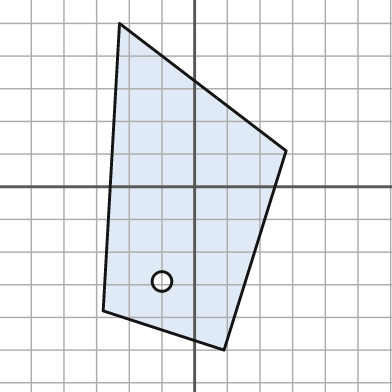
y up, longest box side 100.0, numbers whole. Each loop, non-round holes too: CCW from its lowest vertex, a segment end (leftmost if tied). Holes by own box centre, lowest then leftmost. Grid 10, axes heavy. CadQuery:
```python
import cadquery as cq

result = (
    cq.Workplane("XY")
    .moveTo(9.0, -50.0)
    .lineTo(28.0, 11.0)
    .lineTo(-23.0, 50.0)
    .lineTo(-28.0, -38.0)
    .close()
    .moveTo(-10.0, -29.0)
    .circle(3.0)
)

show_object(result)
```